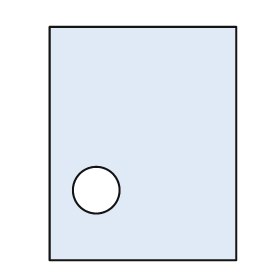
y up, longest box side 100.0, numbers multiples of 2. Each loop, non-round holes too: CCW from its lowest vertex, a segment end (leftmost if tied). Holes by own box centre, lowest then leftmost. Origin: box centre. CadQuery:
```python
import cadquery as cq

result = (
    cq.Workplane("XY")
    .moveTo(-40.0, -50.0)
    .lineTo(40.0, -50.0)
    .lineTo(40.0, 50.0)
    .lineTo(-40.0, 50.0)
    .close()
    .moveTo(-20.0, -20.0)
    .circle(10.0)
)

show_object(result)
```